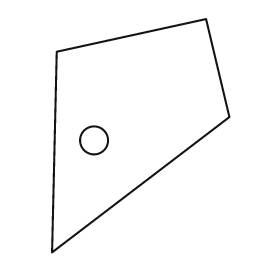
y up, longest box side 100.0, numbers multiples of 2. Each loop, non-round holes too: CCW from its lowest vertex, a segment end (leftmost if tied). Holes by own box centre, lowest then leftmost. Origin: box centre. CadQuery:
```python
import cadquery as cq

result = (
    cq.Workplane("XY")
    .moveTo(-38.0, -50.0)
    .lineTo(38.0, 8.0)
    .lineTo(28.0, 50.0)
    .lineTo(-36.0, 36.0)
    .close()
    .moveTo(-20.0, -2.0)
    .circle(6.0)
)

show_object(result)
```